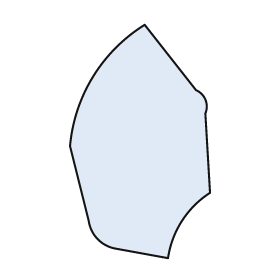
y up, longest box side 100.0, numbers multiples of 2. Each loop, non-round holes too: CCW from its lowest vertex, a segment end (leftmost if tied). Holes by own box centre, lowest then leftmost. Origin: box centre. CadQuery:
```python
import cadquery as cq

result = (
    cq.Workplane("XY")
    .moveTo(12.0, -50.0)
    .threePointArc((18.0, -34.0), (30.0, -22.0))
    .lineTo(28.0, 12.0)
    .threePointArc((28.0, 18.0), (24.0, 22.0))
    .lineTo(2.0, 50.0)
    .threePointArc((-20.0, 28.0), (-30.0, -2.0))
    .lineTo(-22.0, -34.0)
    .threePointArc((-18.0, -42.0), (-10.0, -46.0))
    .close()
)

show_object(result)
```